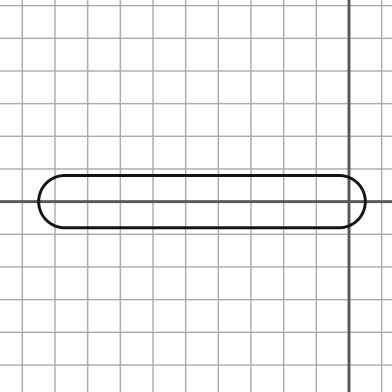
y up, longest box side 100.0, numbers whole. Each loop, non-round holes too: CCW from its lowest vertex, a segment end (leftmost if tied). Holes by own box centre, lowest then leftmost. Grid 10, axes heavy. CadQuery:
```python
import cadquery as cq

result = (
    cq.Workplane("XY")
    .moveTo(-87.0, -8.0)
    .lineTo(-3.0, -8.0)
    .threePointArc((5.0, 0.0), (-3.0, 8.0))
    .lineTo(-87.0, 8.0)
    .threePointArc((-95.0, 0.0), (-87.0, -8.0))
    .close()
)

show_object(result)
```